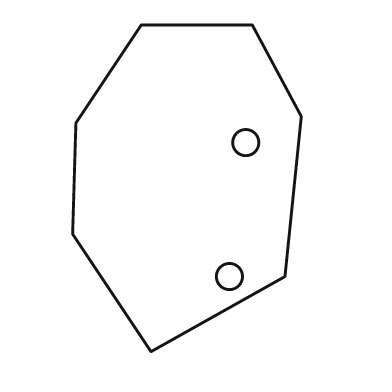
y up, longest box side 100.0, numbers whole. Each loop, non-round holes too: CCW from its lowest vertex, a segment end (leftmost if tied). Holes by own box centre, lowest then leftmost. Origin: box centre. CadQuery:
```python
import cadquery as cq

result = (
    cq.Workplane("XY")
    .moveTo(-11.0, -50.0)
    .lineTo(30.0, -27.0)
    .lineTo(35.0, 22.0)
    .lineTo(20.0, 50.0)
    .lineTo(-14.0, 50.0)
    .lineTo(-34.0, 20.0)
    .lineTo(-35.0, -14.0)
    .close()
    .moveTo(13.0, -27.0)
    .circle(4.0)
    .moveTo(18.0, 14.0)
    .circle(4.0)
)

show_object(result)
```